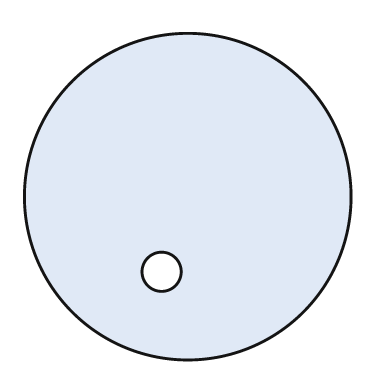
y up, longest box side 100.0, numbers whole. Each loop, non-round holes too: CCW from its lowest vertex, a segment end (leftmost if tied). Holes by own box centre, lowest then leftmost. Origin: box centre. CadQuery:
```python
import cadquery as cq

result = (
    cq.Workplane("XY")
    .moveTo(0.0, 0.0)
    .circle(50.0)
    .moveTo(-8.0, -23.0)
    .circle(6.0)
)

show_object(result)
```